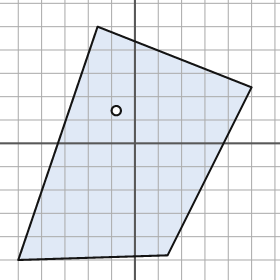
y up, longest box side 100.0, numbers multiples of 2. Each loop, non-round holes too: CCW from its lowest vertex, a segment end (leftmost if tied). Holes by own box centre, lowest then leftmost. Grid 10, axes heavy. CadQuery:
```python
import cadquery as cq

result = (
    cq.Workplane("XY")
    .moveTo(-50.0, -50.0)
    .lineTo(14.0, -48.0)
    .lineTo(50.0, 24.0)
    .lineTo(-16.0, 50.0)
    .close()
    .moveTo(-8.0, 14.0)
    .circle(2.0)
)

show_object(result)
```